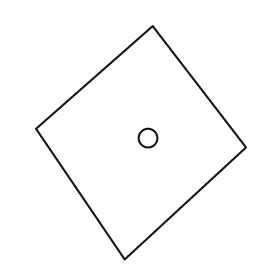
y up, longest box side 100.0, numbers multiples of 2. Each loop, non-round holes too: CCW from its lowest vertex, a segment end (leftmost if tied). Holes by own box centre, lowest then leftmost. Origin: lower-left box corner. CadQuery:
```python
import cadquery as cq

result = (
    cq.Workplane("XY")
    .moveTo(38.0, 0.0)
    .lineTo(90.0, 48.0)
    .lineTo(50.0, 100.0)
    .lineTo(0.0, 56.0)
    .close()
    .moveTo(48.0, 52.0)
    .circle(4.0)
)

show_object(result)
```